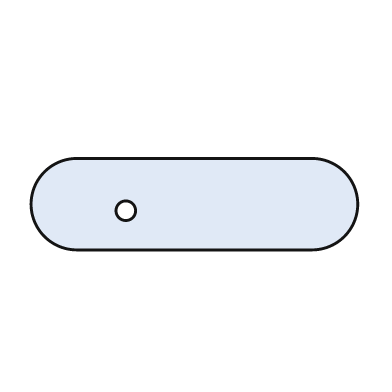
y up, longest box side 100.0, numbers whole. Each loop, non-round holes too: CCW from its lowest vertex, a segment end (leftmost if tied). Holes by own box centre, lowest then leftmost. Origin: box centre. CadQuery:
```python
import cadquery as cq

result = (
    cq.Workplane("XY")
    .moveTo(-36.0, -14.0)
    .lineTo(36.0, -14.0)
    .threePointArc((50.0, 0.0), (36.0, 14.0))
    .lineTo(-36.0, 14.0)
    .threePointArc((-50.0, 0.0), (-36.0, -14.0))
    .close()
    .moveTo(-21.0, -2.0)
    .circle(3.0)
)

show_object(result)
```